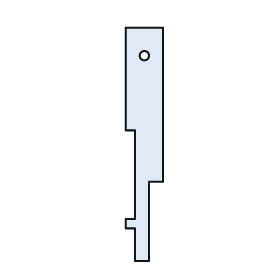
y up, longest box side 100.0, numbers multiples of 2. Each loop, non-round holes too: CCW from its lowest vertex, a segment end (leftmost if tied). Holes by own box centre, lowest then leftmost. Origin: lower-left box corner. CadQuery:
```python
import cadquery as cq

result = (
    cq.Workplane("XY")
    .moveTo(4.0, 0.0)
    .lineTo(10.0, 0.0)
    .lineTo(10.0, 34.0)
    .lineTo(16.0, 34.0)
    .lineTo(16.0, 100.0)
    .lineTo(0.0, 100.0)
    .lineTo(0.0, 56.0)
    .lineTo(4.0, 56.0)
    .lineTo(4.0, 18.0)
    .lineTo(0.0, 18.0)
    .lineTo(0.0, 14.0)
    .lineTo(4.0, 14.0)
    .close()
    .moveTo(8.0, 88.0)
    .circle(2.0)
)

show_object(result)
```